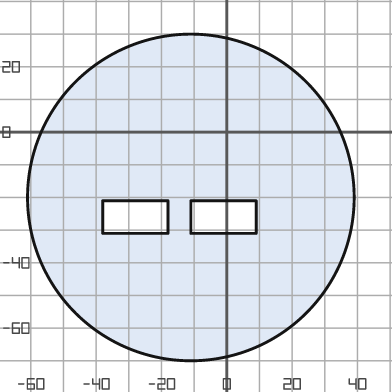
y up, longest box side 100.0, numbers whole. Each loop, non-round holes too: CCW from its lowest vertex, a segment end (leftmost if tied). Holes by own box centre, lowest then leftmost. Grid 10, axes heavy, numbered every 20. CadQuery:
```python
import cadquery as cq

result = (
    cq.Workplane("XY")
    .moveTo(-11.0, -20.0)
    .circle(50.0)
    .moveTo(-38.0, -31.0)
    .lineTo(-18.0, -31.0)
    .lineTo(-18.0, -21.0)
    .lineTo(-38.0, -21.0)
    .close()
    .moveTo(-11.0, -31.0)
    .lineTo(9.0, -31.0)
    .lineTo(9.0, -21.0)
    .lineTo(-11.0, -21.0)
    .close()
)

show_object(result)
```